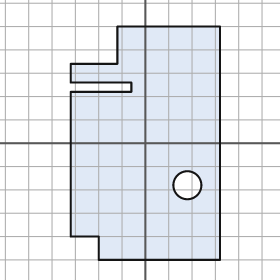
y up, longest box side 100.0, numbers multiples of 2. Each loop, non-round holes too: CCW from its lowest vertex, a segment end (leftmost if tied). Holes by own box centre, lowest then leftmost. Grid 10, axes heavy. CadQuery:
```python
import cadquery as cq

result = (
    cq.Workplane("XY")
    .moveTo(-20.0, -50.0)
    .lineTo(32.0, -50.0)
    .lineTo(32.0, 50.0)
    .lineTo(-12.0, 50.0)
    .lineTo(-12.0, 34.0)
    .lineTo(-32.0, 34.0)
    .lineTo(-32.0, 26.0)
    .lineTo(-6.0, 26.0)
    .lineTo(-6.0, 22.0)
    .lineTo(-32.0, 22.0)
    .lineTo(-32.0, -40.0)
    .lineTo(-20.0, -40.0)
    .close()
    .moveTo(18.0, -18.0)
    .circle(6.0)
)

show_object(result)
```